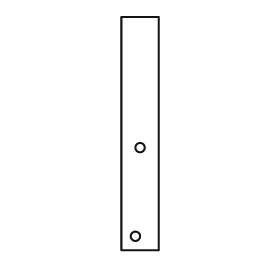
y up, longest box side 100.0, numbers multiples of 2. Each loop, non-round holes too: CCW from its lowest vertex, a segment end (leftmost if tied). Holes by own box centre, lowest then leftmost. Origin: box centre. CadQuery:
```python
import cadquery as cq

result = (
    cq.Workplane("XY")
    .moveTo(-8.0, -50.0)
    .lineTo(8.0, -50.0)
    .lineTo(8.0, 50.0)
    .lineTo(-8.0, 50.0)
    .close()
    .moveTo(-2.0, -44.0)
    .circle(2.0)
    .moveTo(0.0, -6.0)
    .circle(2.0)
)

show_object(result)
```